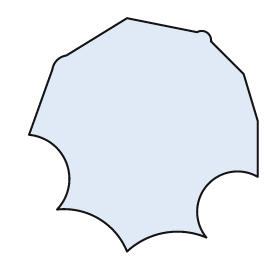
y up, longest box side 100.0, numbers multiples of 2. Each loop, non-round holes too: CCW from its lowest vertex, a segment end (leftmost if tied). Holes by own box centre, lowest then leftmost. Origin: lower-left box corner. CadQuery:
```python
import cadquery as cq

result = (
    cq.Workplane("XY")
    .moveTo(42.0, 0.0)
    .threePointArc((58.0, 8.0), (76.0, 6.0))
    .threePointArc((76.0, 28.0), (98.0, 32.0))
    .lineTo(98.0, 56.0)
    .lineTo(92.0, 76.0)
    .lineTo(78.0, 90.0)
    .threePointArc((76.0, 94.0), (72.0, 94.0))
    .lineTo(42.0, 100.0)
    .lineTo(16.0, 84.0)
    .threePointArc((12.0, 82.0), (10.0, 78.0))
    .lineTo(0.0, 50.0)
    .threePointArc((16.0, 38.0), (12.0, 18.0))
    .threePointArc((30.0, 14.0), (42.0, 0.0))
    .close()
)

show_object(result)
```